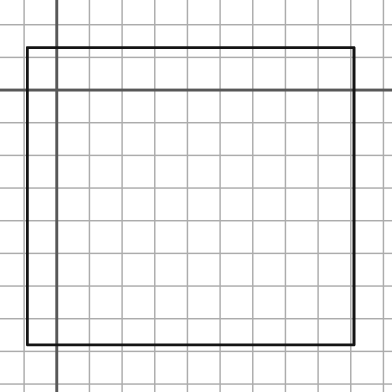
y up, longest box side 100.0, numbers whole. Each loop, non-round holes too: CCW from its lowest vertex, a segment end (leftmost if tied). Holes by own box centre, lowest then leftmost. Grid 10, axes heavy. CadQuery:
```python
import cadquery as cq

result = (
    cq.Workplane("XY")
    .moveTo(-9.0, -78.0)
    .lineTo(91.0, -78.0)
    .lineTo(91.0, 13.0)
    .lineTo(-9.0, 13.0)
    .close()
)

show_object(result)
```